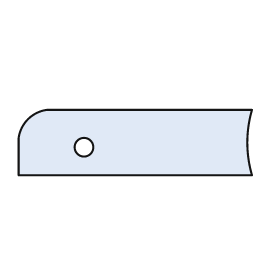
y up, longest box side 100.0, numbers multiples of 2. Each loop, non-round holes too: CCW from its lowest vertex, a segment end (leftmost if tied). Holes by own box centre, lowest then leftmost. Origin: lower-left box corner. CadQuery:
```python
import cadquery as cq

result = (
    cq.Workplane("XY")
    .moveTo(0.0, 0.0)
    .lineTo(100.0, 0.0)
    .threePointArc((98.0, 14.0), (100.0, 28.0))
    .lineTo(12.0, 28.0)
    .threePointArc((4.0, 24.0), (0.0, 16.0))
    .close()
    .moveTo(28.0, 12.0)
    .circle(4.0)
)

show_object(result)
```